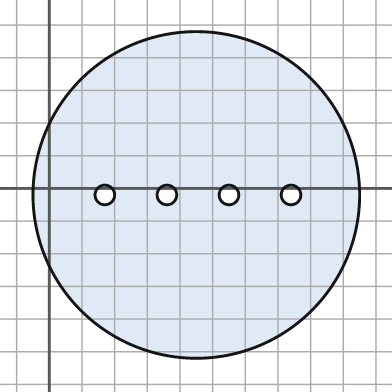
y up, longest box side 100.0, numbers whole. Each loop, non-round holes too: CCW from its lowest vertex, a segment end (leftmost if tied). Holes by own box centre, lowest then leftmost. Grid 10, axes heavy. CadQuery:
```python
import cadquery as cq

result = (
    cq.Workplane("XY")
    .moveTo(45.0, -2.0)
    .circle(50.0)
    .moveTo(17.0, -2.0)
    .circle(3.0)
    .moveTo(36.0, -2.0)
    .circle(3.0)
    .moveTo(55.0, -2.0)
    .circle(3.0)
    .moveTo(74.0, -2.0)
    .circle(3.0)
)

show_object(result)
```